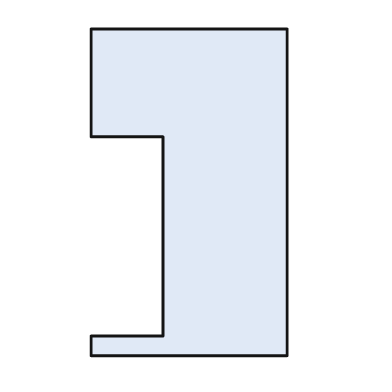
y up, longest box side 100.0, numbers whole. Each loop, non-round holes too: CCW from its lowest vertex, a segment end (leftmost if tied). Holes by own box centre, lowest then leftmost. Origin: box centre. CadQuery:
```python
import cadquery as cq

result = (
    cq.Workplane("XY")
    .moveTo(-30.0, -50.0)
    .lineTo(30.0, -50.0)
    .lineTo(30.0, 50.0)
    .lineTo(-30.0, 50.0)
    .lineTo(-30.0, 17.0)
    .lineTo(-8.0, 17.0)
    .lineTo(-8.0, -44.0)
    .lineTo(-30.0, -44.0)
    .close()
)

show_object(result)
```